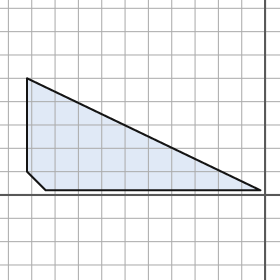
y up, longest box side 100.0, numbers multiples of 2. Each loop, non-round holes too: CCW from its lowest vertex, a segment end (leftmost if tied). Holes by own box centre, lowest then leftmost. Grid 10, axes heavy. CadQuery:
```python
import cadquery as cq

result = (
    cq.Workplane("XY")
    .moveTo(-94.0, 2.0)
    .lineTo(-2.0, 2.0)
    .lineTo(-102.0, 50.0)
    .lineTo(-102.0, 10.0)
    .close()
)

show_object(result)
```